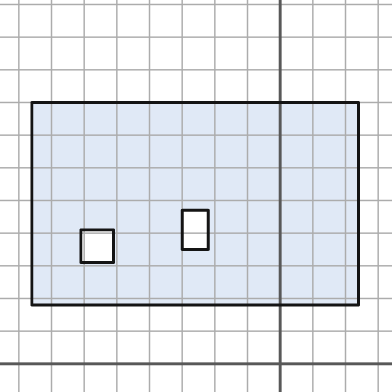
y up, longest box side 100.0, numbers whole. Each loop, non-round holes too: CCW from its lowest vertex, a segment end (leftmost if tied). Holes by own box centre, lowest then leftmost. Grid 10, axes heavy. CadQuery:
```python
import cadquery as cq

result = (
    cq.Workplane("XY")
    .moveTo(-76.0, 18.0)
    .lineTo(24.0, 18.0)
    .lineTo(24.0, 80.0)
    .lineTo(-76.0, 80.0)
    .close()
    .moveTo(-61.0, 31.0)
    .lineTo(-51.0, 31.0)
    .lineTo(-51.0, 41.0)
    .lineTo(-61.0, 41.0)
    .close()
    .moveTo(-30.0, 35.0)
    .lineTo(-22.0, 35.0)
    .lineTo(-22.0, 47.0)
    .lineTo(-30.0, 47.0)
    .close()
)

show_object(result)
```